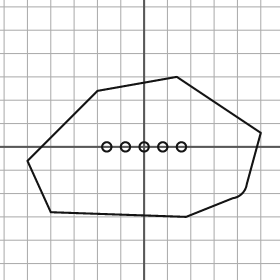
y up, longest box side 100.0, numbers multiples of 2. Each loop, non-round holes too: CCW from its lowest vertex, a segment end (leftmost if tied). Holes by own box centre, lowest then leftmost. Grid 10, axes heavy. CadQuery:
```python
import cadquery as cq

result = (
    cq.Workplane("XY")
    .moveTo(18.0, -30.0)
    .lineTo(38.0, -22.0)
    .threePointArc((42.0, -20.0), (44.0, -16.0))
    .lineTo(50.0, 6.0)
    .lineTo(14.0, 30.0)
    .lineTo(-20.0, 24.0)
    .lineTo(-50.0, -6.0)
    .lineTo(-40.0, -28.0)
    .close()
    .moveTo(-16.0, 0.0)
    .circle(2.0)
    .moveTo(-8.0, 0.0)
    .circle(2.0)
    .moveTo(0.0, 0.0)
    .circle(2.0)
    .moveTo(8.0, 0.0)
    .circle(2.0)
    .moveTo(16.0, 0.0)
    .circle(2.0)
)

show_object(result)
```